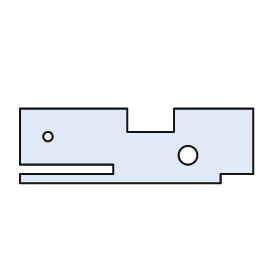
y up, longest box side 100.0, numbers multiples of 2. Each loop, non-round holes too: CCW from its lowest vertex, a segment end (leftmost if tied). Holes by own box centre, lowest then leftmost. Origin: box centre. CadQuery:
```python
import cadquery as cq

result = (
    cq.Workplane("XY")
    .moveTo(-50.0, -16.0)
    .lineTo(36.0, -16.0)
    .lineTo(36.0, -12.0)
    .lineTo(50.0, -12.0)
    .lineTo(50.0, 16.0)
    .lineTo(16.0, 16.0)
    .lineTo(16.0, 6.0)
    .lineTo(-4.0, 6.0)
    .lineTo(-4.0, 16.0)
    .lineTo(-50.0, 16.0)
    .lineTo(-50.0, -8.0)
    .lineTo(-10.0, -8.0)
    .lineTo(-10.0, -12.0)
    .lineTo(-50.0, -12.0)
    .close()
    .moveTo(22.0, -4.0)
    .circle(4.0)
    .moveTo(-38.0, 4.0)
    .circle(2.0)
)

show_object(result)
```